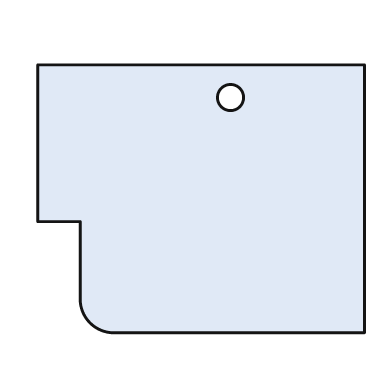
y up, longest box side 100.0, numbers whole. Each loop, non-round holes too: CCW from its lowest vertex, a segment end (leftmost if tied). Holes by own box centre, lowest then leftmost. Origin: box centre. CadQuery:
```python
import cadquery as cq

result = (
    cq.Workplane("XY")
    .moveTo(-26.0, -41.0)
    .lineTo(50.0, -41.0)
    .lineTo(50.0, 41.0)
    .lineTo(-50.0, 41.0)
    .lineTo(-50.0, -7.0)
    .lineTo(-37.0, -7.0)
    .lineTo(-37.0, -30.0)
    .threePointArc((-34.0, -38.0), (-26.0, -41.0))
    .close()
    .moveTo(9.0, 31.0)
    .circle(4.0)
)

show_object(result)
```